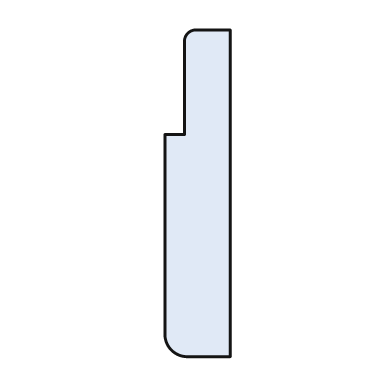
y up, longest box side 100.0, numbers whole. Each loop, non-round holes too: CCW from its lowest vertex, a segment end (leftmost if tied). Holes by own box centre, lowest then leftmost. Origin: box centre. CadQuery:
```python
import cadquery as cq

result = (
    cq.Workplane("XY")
    .moveTo(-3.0, -50.0)
    .lineTo(10.0, -50.0)
    .lineTo(10.0, 50.0)
    .lineTo(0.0, 50.0)
    .threePointArc((-3.0, 49.0), (-4.0, 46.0))
    .lineTo(-4.0, 18.0)
    .lineTo(-10.0, 18.0)
    .lineTo(-10.0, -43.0)
    .threePointArc((-8.0, -48.0), (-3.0, -50.0))
    .close()
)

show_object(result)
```